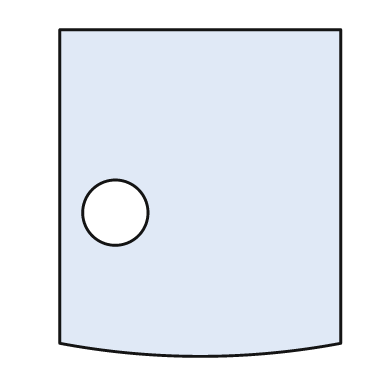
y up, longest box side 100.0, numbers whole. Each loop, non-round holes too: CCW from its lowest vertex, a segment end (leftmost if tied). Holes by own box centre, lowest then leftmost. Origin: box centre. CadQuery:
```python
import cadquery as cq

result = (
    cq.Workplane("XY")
    .moveTo(-43.0, -46.0)
    .threePointArc((0.0, -50.0), (43.0, -46.0))
    .lineTo(43.0, 50.0)
    .lineTo(-43.0, 50.0)
    .close()
    .moveTo(-26.0, -6.0)
    .circle(10.0)
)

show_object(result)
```